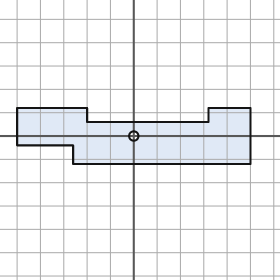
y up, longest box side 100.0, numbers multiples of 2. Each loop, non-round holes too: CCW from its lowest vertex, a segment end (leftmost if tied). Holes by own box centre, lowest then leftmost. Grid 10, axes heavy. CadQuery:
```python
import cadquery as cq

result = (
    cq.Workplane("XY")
    .moveTo(-26.0, -12.0)
    .lineTo(50.0, -12.0)
    .lineTo(50.0, 12.0)
    .lineTo(32.0, 12.0)
    .lineTo(32.0, 6.0)
    .lineTo(-20.0, 6.0)
    .lineTo(-20.0, 12.0)
    .lineTo(-50.0, 12.0)
    .lineTo(-50.0, -4.0)
    .lineTo(-26.0, -4.0)
    .close()
    .moveTo(0.0, 0.0)
    .circle(2.0)
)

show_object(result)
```